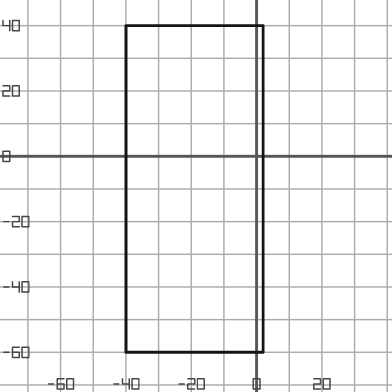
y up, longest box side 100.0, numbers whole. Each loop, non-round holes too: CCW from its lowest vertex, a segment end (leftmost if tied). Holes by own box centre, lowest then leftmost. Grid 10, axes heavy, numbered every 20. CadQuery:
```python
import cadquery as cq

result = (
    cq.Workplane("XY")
    .moveTo(-40.0, -60.0)
    .lineTo(2.0, -60.0)
    .lineTo(2.0, 40.0)
    .lineTo(-40.0, 40.0)
    .close()
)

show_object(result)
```